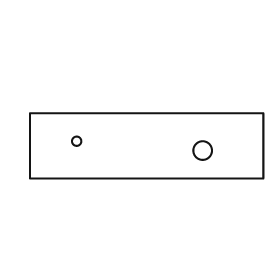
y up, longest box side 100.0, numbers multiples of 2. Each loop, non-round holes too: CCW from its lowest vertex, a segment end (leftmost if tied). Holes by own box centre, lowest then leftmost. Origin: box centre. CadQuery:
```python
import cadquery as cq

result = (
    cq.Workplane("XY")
    .moveTo(-50.0, -14.0)
    .lineTo(50.0, -14.0)
    .lineTo(50.0, 14.0)
    .lineTo(-50.0, 14.0)
    .close()
    .moveTo(24.0, -2.0)
    .circle(4.0)
    .moveTo(-30.0, 2.0)
    .circle(2.0)
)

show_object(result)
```